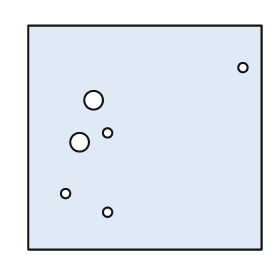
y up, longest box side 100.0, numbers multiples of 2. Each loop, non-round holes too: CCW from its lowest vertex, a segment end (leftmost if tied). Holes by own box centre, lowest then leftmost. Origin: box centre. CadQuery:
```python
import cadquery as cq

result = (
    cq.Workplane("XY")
    .moveTo(-50.0, -48.0)
    .lineTo(50.0, -48.0)
    .lineTo(50.0, 48.0)
    .lineTo(-50.0, 48.0)
    .close()
    .moveTo(-16.0, -32.0)
    .circle(2.0)
    .moveTo(-34.0, -24.0)
    .circle(2.0)
    .moveTo(-28.0, -2.0)
    .circle(4.0)
    .moveTo(-16.0, 2.0)
    .circle(2.0)
    .moveTo(-22.0, 16.0)
    .circle(4.0)
    .moveTo(42.0, 30.0)
    .circle(2.0)
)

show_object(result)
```